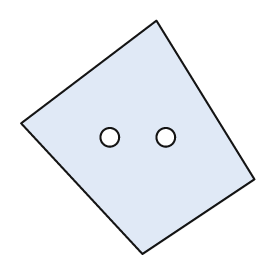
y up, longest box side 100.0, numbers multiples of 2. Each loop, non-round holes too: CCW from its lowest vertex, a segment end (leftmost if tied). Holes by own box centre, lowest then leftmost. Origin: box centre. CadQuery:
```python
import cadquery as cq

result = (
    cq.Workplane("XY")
    .moveTo(2.0, -50.0)
    .lineTo(50.0, -18.0)
    .lineTo(8.0, 50.0)
    .lineTo(-50.0, 6.0)
    .close()
    .moveTo(-12.0, 0.0)
    .circle(4.0)
    .moveTo(12.0, 0.0)
    .circle(4.0)
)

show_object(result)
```